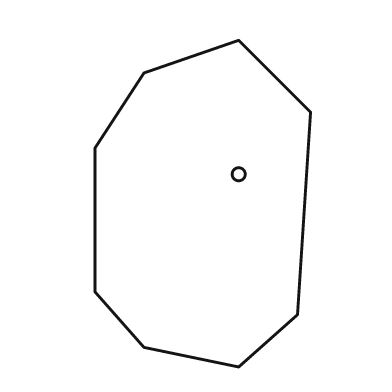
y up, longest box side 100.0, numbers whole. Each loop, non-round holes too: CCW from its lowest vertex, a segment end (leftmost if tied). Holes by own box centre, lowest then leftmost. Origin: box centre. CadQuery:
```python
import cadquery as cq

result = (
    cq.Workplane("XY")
    .moveTo(11.0, -50.0)
    .lineTo(29.0, -34.0)
    .lineTo(33.0, 28.0)
    .lineTo(11.0, 50.0)
    .lineTo(-18.0, 40.0)
    .lineTo(-33.0, 17.0)
    .lineTo(-33.0, -27.0)
    .lineTo(-18.0, -44.0)
    .close()
    .moveTo(11.0, 9.0)
    .circle(2.0)
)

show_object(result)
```